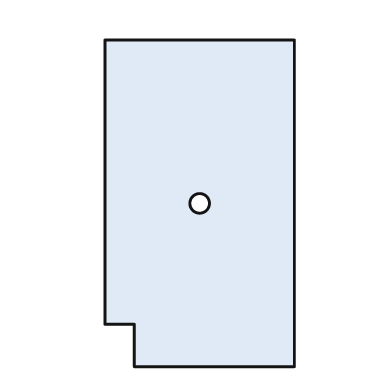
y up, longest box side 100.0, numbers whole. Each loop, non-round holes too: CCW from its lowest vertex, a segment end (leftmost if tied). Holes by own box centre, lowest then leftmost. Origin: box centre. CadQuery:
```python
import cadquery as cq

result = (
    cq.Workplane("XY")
    .moveTo(-20.0, -50.0)
    .lineTo(29.0, -50.0)
    .lineTo(29.0, 50.0)
    .lineTo(-29.0, 50.0)
    .lineTo(-29.0, -37.0)
    .lineTo(-20.0, -37.0)
    .close()
    .moveTo(0.0, 0.0)
    .circle(3.0)
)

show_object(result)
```